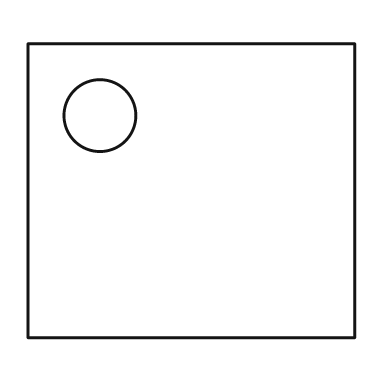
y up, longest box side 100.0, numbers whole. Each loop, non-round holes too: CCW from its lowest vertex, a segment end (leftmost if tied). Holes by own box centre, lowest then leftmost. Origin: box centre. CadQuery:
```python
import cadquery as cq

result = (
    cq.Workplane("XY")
    .moveTo(-50.0, -45.0)
    .lineTo(50.0, -45.0)
    .lineTo(50.0, 45.0)
    .lineTo(-50.0, 45.0)
    .close()
    .moveTo(-28.0, 23.0)
    .circle(11.0)
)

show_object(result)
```